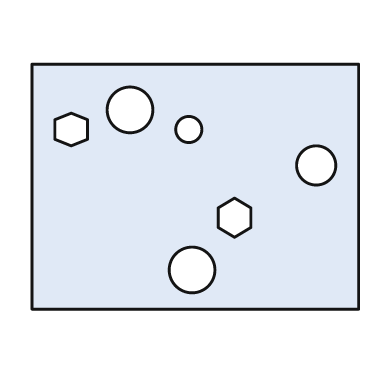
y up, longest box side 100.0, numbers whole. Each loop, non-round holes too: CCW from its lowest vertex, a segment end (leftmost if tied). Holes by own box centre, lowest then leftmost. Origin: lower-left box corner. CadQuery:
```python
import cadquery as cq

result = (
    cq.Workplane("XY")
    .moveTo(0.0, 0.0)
    .lineTo(100.0, 0.0)
    .lineTo(100.0, 75.0)
    .lineTo(0.0, 75.0)
    .close()
    .moveTo(49.0, 12.0)
    .circle(7.0)
    .moveTo(62.0, 22.0)
    .lineTo(67.0, 25.0)
    .lineTo(67.0, 31.0)
    .lineTo(62.0, 34.0)
    .lineTo(57.0, 31.0)
    .lineTo(57.0, 25.0)
    .close()
    .moveTo(87.0, 44.0)
    .circle(6.0)
    .moveTo(12.0, 50.0)
    .lineTo(17.0, 52.0)
    .lineTo(17.0, 58.0)
    .lineTo(12.0, 60.0)
    .lineTo(7.0, 58.0)
    .lineTo(7.0, 52.0)
    .close()
    .moveTo(48.0, 55.0)
    .circle(4.0)
    .moveTo(30.0, 61.0)
    .circle(7.0)
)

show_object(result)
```